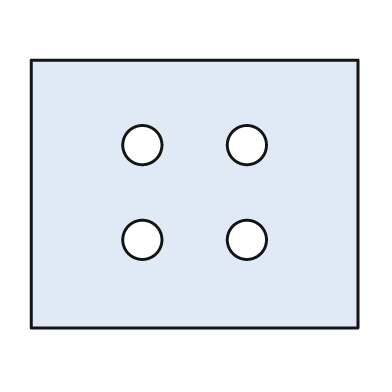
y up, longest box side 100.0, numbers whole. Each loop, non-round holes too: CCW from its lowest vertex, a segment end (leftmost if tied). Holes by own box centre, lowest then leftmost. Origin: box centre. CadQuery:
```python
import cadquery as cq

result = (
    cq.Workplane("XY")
    .moveTo(-50.0, -41.0)
    .lineTo(50.0, -41.0)
    .lineTo(50.0, 41.0)
    .lineTo(-50.0, 41.0)
    .close()
    .moveTo(-16.0, -14.0)
    .circle(6.0)
    .moveTo(16.0, -14.0)
    .circle(6.0)
    .moveTo(-16.0, 15.0)
    .circle(6.0)
    .moveTo(16.0, 15.0)
    .circle(6.0)
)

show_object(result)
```